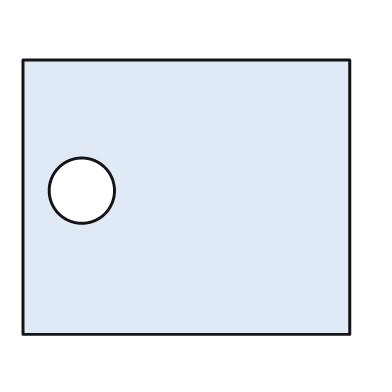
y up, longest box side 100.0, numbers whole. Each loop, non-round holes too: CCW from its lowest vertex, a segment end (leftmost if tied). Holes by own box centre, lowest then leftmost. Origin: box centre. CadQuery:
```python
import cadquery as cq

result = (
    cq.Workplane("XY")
    .moveTo(-50.0, -42.0)
    .lineTo(50.0, -42.0)
    .lineTo(50.0, 42.0)
    .lineTo(-50.0, 42.0)
    .close()
    .moveTo(-32.0, 2.0)
    .circle(10.0)
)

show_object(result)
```